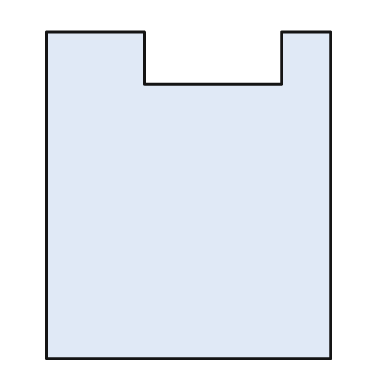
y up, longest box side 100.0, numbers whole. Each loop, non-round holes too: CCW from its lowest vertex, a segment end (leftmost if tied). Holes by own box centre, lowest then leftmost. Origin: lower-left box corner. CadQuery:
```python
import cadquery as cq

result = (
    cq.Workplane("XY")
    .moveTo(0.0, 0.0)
    .lineTo(87.0, 0.0)
    .lineTo(87.0, 100.0)
    .lineTo(72.0, 100.0)
    .lineTo(72.0, 84.0)
    .lineTo(30.0, 84.0)
    .lineTo(30.0, 100.0)
    .lineTo(0.0, 100.0)
    .close()
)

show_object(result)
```